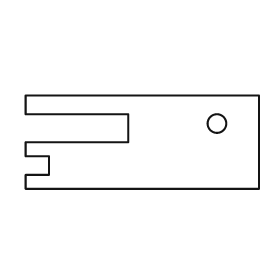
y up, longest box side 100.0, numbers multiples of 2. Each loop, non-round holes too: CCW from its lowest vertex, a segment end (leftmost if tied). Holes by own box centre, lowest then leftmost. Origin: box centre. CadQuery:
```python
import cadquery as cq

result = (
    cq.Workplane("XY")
    .moveTo(-50.0, -20.0)
    .lineTo(50.0, -20.0)
    .lineTo(50.0, 20.0)
    .lineTo(-50.0, 20.0)
    .lineTo(-50.0, 12.0)
    .lineTo(-6.0, 12.0)
    .lineTo(-6.0, 0.0)
    .lineTo(-50.0, 0.0)
    .lineTo(-50.0, -6.0)
    .lineTo(-40.0, -6.0)
    .lineTo(-40.0, -14.0)
    .lineTo(-50.0, -14.0)
    .close()
    .moveTo(32.0, 8.0)
    .circle(4.0)
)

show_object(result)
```